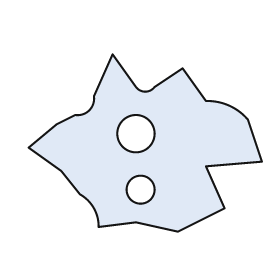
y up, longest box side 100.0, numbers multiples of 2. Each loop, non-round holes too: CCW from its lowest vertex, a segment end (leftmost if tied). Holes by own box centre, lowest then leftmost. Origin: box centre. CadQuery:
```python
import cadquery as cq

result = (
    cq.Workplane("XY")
    .moveTo(14.0, -38.0)
    .lineTo(34.0, -28.0)
    .lineTo(26.0, -10.0)
    .lineTo(50.0, -8.0)
    .lineTo(44.0, 10.0)
    .threePointArc((36.0, 16.0), (26.0, 18.0))
    .lineTo(16.0, 32.0)
    .lineTo(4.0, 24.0)
    .threePointArc((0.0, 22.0), (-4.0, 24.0))
    .lineTo(-14.0, 38.0)
    .lineTo(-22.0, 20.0)
    .threePointArc((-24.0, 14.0), (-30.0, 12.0))
    .lineTo(-38.0, 8.0)
    .lineTo(-50.0, -2.0)
    .lineTo(-36.0, -12.0)
    .lineTo(-28.0, -22.0)
    .threePointArc((-22.0, -28.0), (-20.0, -36.0))
    .lineTo(-4.0, -34.0)
    .close()
    .moveTo(-2.0, -20.0)
    .circle(6.0)
    .moveTo(-4.0, 4.0)
    .circle(8.0)
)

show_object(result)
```